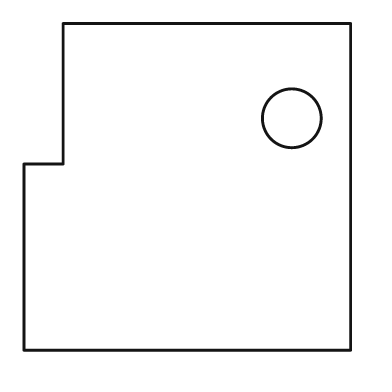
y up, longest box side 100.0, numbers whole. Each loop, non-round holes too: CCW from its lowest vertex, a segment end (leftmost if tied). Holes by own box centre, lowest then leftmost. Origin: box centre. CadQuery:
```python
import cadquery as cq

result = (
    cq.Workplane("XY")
    .moveTo(-50.0, -50.0)
    .lineTo(50.0, -50.0)
    .lineTo(50.0, 50.0)
    .lineTo(-38.0, 50.0)
    .lineTo(-38.0, 7.0)
    .lineTo(-50.0, 7.0)
    .close()
    .moveTo(32.0, 21.0)
    .circle(9.0)
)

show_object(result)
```